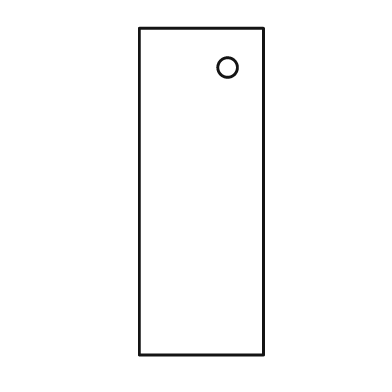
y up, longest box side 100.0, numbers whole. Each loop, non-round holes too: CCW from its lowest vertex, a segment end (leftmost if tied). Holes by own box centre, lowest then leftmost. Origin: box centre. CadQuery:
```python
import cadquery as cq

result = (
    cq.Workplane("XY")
    .moveTo(-19.0, -50.0)
    .lineTo(19.0, -50.0)
    .lineTo(19.0, 50.0)
    .lineTo(-19.0, 50.0)
    .close()
    .moveTo(8.0, 38.0)
    .circle(3.0)
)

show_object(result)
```